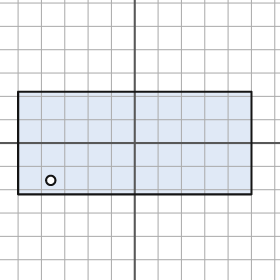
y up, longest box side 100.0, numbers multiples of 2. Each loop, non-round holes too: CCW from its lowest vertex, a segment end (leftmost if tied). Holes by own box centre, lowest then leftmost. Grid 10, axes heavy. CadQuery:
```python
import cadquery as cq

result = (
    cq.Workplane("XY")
    .moveTo(-50.0, -22.0)
    .lineTo(50.0, -22.0)
    .lineTo(50.0, 22.0)
    .lineTo(-50.0, 22.0)
    .close()
    .moveTo(-36.0, -16.0)
    .circle(2.0)
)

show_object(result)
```